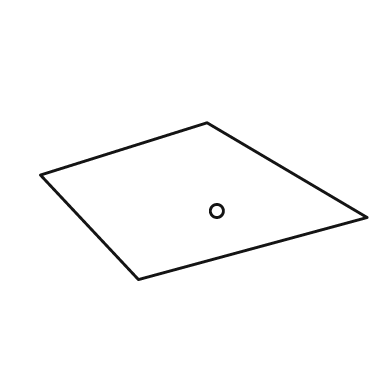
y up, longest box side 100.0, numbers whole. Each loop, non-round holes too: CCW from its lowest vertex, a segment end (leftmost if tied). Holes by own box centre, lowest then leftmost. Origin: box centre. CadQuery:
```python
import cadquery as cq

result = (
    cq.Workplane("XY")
    .moveTo(-20.0, -24.0)
    .lineTo(50.0, -5.0)
    .lineTo(1.0, 24.0)
    .lineTo(-50.0, 8.0)
    .close()
    .moveTo(4.0, -3.0)
    .circle(2.0)
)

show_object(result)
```